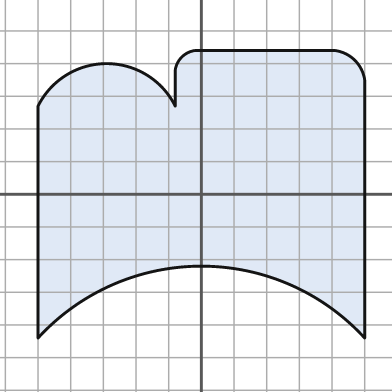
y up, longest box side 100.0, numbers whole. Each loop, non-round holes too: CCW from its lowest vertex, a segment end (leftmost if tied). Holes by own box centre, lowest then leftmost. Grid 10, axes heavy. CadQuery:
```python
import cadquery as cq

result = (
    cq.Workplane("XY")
    .moveTo(-50.0, -44.0)
    .threePointArc((0.0, -22.0), (50.0, -44.0))
    .lineTo(50.0, 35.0)
    .threePointArc((47.0, 41.0), (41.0, 44.0))
    .lineTo(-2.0, 44.0)
    .threePointArc((-6.0, 42.0), (-8.0, 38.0))
    .lineTo(-8.0, 27.0)
    .threePointArc((-29.0, 40.0), (-50.0, 27.0))
    .close()
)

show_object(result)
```